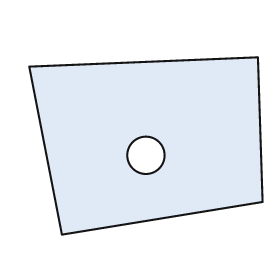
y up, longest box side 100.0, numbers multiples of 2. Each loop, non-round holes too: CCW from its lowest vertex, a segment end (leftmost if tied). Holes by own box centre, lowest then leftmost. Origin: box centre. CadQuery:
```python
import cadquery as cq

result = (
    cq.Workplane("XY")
    .moveTo(-36.0, -38.0)
    .lineTo(50.0, -24.0)
    .lineTo(48.0, 38.0)
    .lineTo(-50.0, 34.0)
    .close()
    .moveTo(0.0, -4.0)
    .circle(8.0)
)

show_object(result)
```